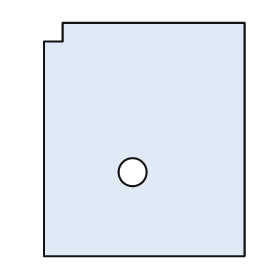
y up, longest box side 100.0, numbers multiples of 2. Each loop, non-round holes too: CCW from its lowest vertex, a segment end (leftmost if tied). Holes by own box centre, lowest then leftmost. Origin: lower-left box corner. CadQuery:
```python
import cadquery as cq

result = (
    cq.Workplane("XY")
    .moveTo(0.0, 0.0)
    .lineTo(86.0, 0.0)
    .lineTo(86.0, 100.0)
    .lineTo(8.0, 100.0)
    .lineTo(8.0, 92.0)
    .lineTo(0.0, 92.0)
    .close()
    .moveTo(38.0, 36.0)
    .circle(6.0)
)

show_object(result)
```